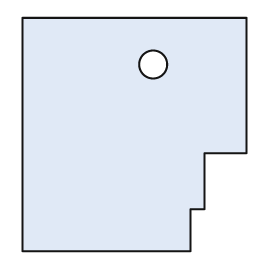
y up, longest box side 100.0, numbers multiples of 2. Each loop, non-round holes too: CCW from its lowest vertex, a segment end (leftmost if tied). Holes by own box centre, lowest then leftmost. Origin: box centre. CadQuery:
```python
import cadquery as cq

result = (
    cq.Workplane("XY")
    .moveTo(-48.0, -50.0)
    .lineTo(24.0, -50.0)
    .lineTo(24.0, -32.0)
    .lineTo(30.0, -32.0)
    .lineTo(30.0, -8.0)
    .lineTo(48.0, -8.0)
    .lineTo(48.0, 50.0)
    .lineTo(-48.0, 50.0)
    .close()
    .moveTo(8.0, 30.0)
    .circle(6.0)
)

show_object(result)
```